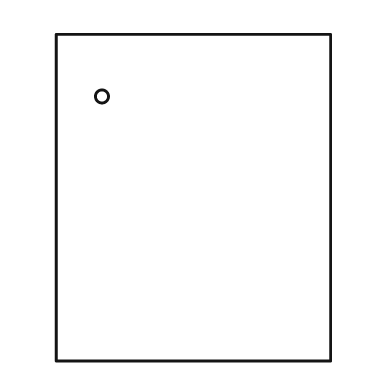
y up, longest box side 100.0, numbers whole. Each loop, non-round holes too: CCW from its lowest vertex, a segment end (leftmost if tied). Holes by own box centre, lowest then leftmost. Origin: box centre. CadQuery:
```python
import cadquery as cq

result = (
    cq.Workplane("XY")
    .moveTo(-42.0, -50.0)
    .lineTo(42.0, -50.0)
    .lineTo(42.0, 50.0)
    .lineTo(-42.0, 50.0)
    .close()
    .moveTo(-28.0, 31.0)
    .circle(2.0)
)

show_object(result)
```